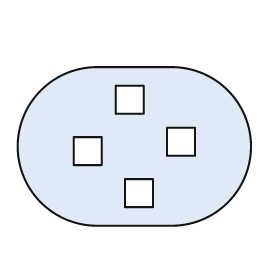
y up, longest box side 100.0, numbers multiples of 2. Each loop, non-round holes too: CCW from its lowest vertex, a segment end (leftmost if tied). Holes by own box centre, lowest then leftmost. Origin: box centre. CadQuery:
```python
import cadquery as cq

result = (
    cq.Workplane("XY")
    .moveTo(-16.0, -34.0)
    .lineTo(16.0, -34.0)
    .threePointArc((50.0, 0.0), (16.0, 34.0))
    .lineTo(-16.0, 34.0)
    .threePointArc((-50.0, 0.0), (-16.0, -34.0))
    .close()
    .moveTo(-4.0, -26.0)
    .lineTo(8.0, -26.0)
    .lineTo(8.0, -14.0)
    .lineTo(-4.0, -14.0)
    .close()
    .moveTo(-26.0, -8.0)
    .lineTo(-14.0, -8.0)
    .lineTo(-14.0, 4.0)
    .lineTo(-26.0, 4.0)
    .close()
    .moveTo(14.0, -4.0)
    .lineTo(26.0, -4.0)
    .lineTo(26.0, 8.0)
    .lineTo(14.0, 8.0)
    .close()
    .moveTo(-8.0, 14.0)
    .lineTo(4.0, 14.0)
    .lineTo(4.0, 26.0)
    .lineTo(-8.0, 26.0)
    .close()
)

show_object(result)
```